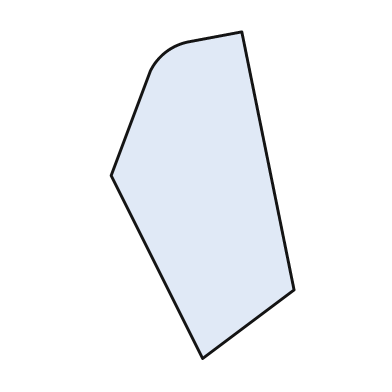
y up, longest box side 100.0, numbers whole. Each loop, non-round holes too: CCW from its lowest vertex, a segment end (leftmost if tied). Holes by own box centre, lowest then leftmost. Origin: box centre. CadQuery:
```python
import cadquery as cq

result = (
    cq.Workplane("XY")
    .moveTo(0.0, -50.0)
    .lineTo(28.0, -29.0)
    .lineTo(12.0, 50.0)
    .lineTo(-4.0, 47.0)
    .threePointArc((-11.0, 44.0), (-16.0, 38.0))
    .lineTo(-28.0, 6.0)
    .close()
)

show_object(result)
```